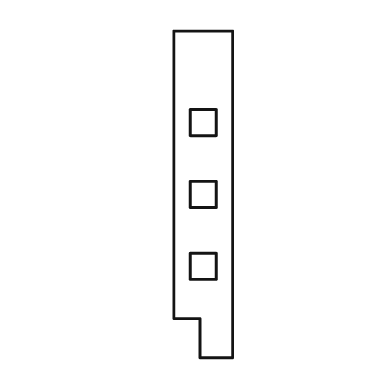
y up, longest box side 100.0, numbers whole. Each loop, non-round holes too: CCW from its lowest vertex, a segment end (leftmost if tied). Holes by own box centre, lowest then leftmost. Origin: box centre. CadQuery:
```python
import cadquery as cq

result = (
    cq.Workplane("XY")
    .moveTo(-1.0, -50.0)
    .lineTo(9.0, -50.0)
    .lineTo(9.0, 50.0)
    .lineTo(-9.0, 50.0)
    .lineTo(-9.0, -38.0)
    .lineTo(-1.0, -38.0)
    .close()
    .moveTo(-4.0, -26.0)
    .lineTo(4.0, -26.0)
    .lineTo(4.0, -18.0)
    .lineTo(-4.0, -18.0)
    .close()
    .moveTo(-4.0, -4.0)
    .lineTo(4.0, -4.0)
    .lineTo(4.0, 4.0)
    .lineTo(-4.0, 4.0)
    .close()
    .moveTo(-4.0, 18.0)
    .lineTo(4.0, 18.0)
    .lineTo(4.0, 26.0)
    .lineTo(-4.0, 26.0)
    .close()
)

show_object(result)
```